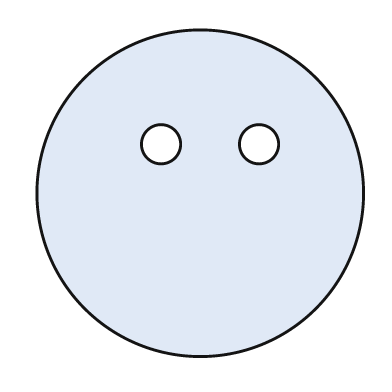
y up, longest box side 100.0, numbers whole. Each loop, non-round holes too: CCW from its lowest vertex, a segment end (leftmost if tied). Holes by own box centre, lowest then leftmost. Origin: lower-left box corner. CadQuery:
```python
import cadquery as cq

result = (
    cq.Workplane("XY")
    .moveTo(50.0, 50.0)
    .circle(50.0)
    .moveTo(38.0, 65.0)
    .circle(6.0)
    .moveTo(68.0, 65.0)
    .circle(6.0)
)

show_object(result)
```